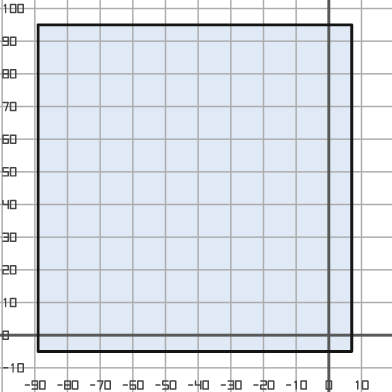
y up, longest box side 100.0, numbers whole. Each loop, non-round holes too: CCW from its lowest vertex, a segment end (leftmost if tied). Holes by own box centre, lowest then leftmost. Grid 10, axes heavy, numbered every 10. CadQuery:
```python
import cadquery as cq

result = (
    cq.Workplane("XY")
    .moveTo(-89.0, -5.0)
    .lineTo(7.0, -5.0)
    .lineTo(7.0, 95.0)
    .lineTo(-89.0, 95.0)
    .close()
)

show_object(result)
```